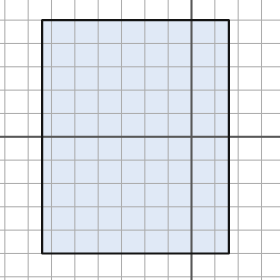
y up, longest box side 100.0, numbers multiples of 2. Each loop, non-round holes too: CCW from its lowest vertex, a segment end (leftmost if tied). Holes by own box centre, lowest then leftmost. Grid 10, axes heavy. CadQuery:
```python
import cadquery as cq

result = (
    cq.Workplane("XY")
    .moveTo(-64.0, -50.0)
    .lineTo(16.0, -50.0)
    .lineTo(16.0, 50.0)
    .lineTo(-64.0, 50.0)
    .close()
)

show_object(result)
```